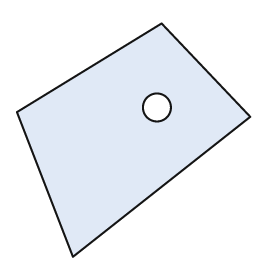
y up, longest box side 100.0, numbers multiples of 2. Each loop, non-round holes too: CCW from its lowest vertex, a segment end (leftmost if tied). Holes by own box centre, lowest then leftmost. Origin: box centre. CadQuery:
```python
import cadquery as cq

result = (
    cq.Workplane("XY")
    .moveTo(-26.0, -50.0)
    .lineTo(50.0, 10.0)
    .lineTo(12.0, 50.0)
    .lineTo(-50.0, 12.0)
    .close()
    .moveTo(10.0, 14.0)
    .circle(6.0)
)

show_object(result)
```